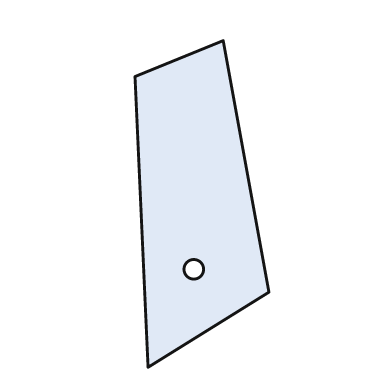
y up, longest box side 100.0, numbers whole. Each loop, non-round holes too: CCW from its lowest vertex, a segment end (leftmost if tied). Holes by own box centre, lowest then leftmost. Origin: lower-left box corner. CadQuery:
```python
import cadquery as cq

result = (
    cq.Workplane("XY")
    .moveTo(4.0, 0.0)
    .lineTo(41.0, 23.0)
    .lineTo(27.0, 100.0)
    .lineTo(0.0, 89.0)
    .close()
    .moveTo(18.0, 30.0)
    .circle(3.0)
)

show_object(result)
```